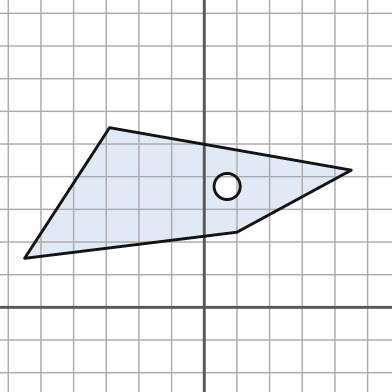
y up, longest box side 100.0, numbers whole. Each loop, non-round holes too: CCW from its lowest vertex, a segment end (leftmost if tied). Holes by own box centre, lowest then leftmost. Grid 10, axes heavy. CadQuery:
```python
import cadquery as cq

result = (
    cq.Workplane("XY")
    .moveTo(-55.0, 15.0)
    .lineTo(10.0, 23.0)
    .lineTo(45.0, 42.0)
    .lineTo(-29.0, 55.0)
    .close()
    .moveTo(7.0, 37.0)
    .circle(4.0)
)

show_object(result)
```